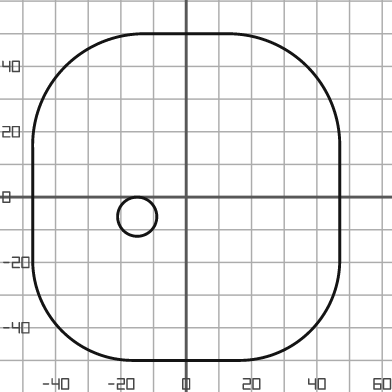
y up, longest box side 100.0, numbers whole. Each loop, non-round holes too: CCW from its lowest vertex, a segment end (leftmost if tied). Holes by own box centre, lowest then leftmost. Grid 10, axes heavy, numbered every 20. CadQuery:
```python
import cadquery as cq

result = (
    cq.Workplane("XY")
    .moveTo(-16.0, -50.0)
    .lineTo(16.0, -50.0)
    .threePointArc((38.0, -41.0), (47.0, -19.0))
    .lineTo(47.0, 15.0)
    .threePointArc((37.0, 40.0), (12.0, 50.0))
    .lineTo(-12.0, 50.0)
    .threePointArc((-37.0, 40.0), (-47.0, 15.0))
    .lineTo(-47.0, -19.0)
    .threePointArc((-38.0, -41.0), (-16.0, -50.0))
    .close()
    .moveTo(-15.0, -6.0)
    .circle(6.0)
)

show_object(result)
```